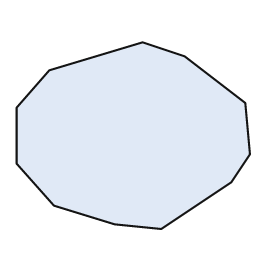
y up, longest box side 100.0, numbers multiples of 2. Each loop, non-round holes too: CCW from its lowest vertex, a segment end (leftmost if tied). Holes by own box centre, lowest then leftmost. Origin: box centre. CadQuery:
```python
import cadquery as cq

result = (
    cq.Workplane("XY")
    .moveTo(12.0, -40.0)
    .lineTo(42.0, -20.0)
    .lineTo(50.0, -8.0)
    .lineTo(48.0, 14.0)
    .lineTo(22.0, 34.0)
    .lineTo(4.0, 40.0)
    .lineTo(-36.0, 28.0)
    .lineTo(-50.0, 12.0)
    .lineTo(-50.0, -12.0)
    .lineTo(-34.0, -30.0)
    .lineTo(-8.0, -38.0)
    .close()
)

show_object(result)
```